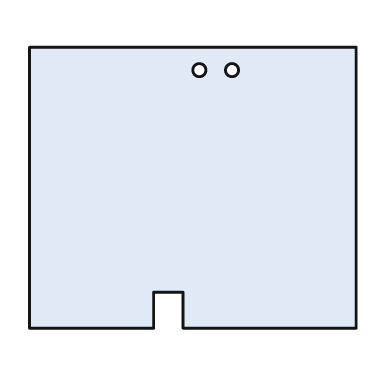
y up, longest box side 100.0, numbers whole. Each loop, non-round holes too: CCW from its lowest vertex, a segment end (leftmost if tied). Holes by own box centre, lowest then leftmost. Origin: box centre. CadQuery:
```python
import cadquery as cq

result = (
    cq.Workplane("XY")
    .moveTo(-50.0, -43.0)
    .lineTo(-12.0, -43.0)
    .lineTo(-12.0, -32.0)
    .lineTo(-3.0, -32.0)
    .lineTo(-3.0, -43.0)
    .lineTo(50.0, -43.0)
    .lineTo(50.0, 43.0)
    .lineTo(-50.0, 43.0)
    .close()
    .moveTo(2.0, 36.0)
    .circle(2.0)
    .moveTo(12.0, 36.0)
    .circle(2.0)
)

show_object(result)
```